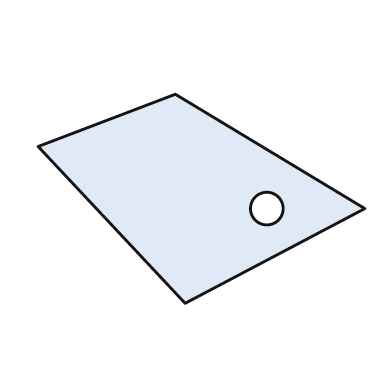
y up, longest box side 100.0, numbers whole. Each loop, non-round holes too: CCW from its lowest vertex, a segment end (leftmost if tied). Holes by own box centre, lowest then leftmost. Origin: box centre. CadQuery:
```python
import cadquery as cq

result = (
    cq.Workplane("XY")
    .moveTo(-5.0, -32.0)
    .lineTo(50.0, -3.0)
    .lineTo(-8.0, 32.0)
    .lineTo(-50.0, 16.0)
    .close()
    .moveTo(20.0, -3.0)
    .circle(5.0)
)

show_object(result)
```